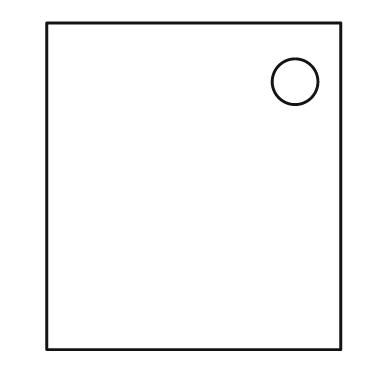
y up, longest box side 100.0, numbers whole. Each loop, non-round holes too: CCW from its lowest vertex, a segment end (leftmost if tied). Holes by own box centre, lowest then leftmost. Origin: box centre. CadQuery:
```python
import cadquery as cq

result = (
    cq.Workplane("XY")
    .moveTo(-45.0, -50.0)
    .lineTo(45.0, -50.0)
    .lineTo(45.0, 50.0)
    .lineTo(-45.0, 50.0)
    .close()
    .moveTo(31.0, 32.0)
    .circle(7.0)
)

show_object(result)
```